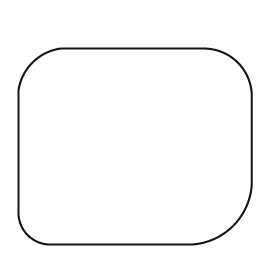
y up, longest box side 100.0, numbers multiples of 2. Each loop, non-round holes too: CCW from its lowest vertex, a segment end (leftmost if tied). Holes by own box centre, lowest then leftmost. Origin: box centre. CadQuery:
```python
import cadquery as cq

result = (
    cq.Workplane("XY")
    .moveTo(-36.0, -42.0)
    .lineTo(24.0, -42.0)
    .threePointArc((42.0, -34.0), (50.0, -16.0))
    .lineTo(50.0, 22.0)
    .threePointArc((44.0, 36.0), (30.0, 42.0))
    .lineTo(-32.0, 42.0)
    .threePointArc((-44.0, 36.0), (-50.0, 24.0))
    .lineTo(-50.0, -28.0)
    .threePointArc((-46.0, -38.0), (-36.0, -42.0))
    .close()
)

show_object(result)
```